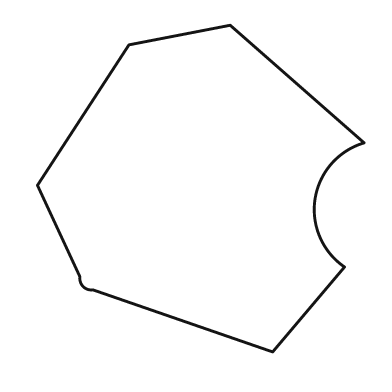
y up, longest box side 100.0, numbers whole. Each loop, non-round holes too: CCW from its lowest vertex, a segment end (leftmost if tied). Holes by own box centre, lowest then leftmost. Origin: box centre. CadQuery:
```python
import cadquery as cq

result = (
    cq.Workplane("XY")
    .moveTo(22.0, -50.0)
    .lineTo(44.0, -24.0)
    .threePointArc((35.0, -3.0), (50.0, 14.0))
    .lineTo(9.0, 50.0)
    .lineTo(-22.0, 44.0)
    .lineTo(-50.0, 1.0)
    .lineTo(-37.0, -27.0)
    .threePointArc((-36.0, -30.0), (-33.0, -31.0))
    .close()
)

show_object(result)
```